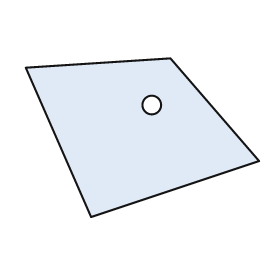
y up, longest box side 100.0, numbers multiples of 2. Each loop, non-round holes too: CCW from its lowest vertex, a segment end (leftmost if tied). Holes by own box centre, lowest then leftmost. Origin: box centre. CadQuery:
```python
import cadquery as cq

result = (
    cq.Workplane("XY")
    .moveTo(-22.0, -34.0)
    .lineTo(50.0, -10.0)
    .lineTo(12.0, 34.0)
    .lineTo(-50.0, 30.0)
    .close()
    .moveTo(4.0, 14.0)
    .circle(4.0)
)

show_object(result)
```